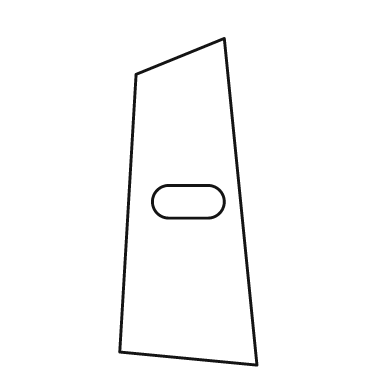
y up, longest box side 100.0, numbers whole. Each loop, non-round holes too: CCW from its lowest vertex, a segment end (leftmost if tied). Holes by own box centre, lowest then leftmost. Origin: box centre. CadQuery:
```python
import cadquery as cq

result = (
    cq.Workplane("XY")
    .moveTo(21.0, -50.0)
    .lineTo(11.0, 50.0)
    .lineTo(-16.0, 39.0)
    .lineTo(-21.0, -46.0)
    .close()
    .moveTo(-6.0, -5.0)
    .lineTo(6.0, -5.0)
    .threePointArc((11.0, 0.0), (6.0, 5.0))
    .lineTo(-6.0, 5.0)
    .threePointArc((-11.0, 0.0), (-6.0, -5.0))
    .close()
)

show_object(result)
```